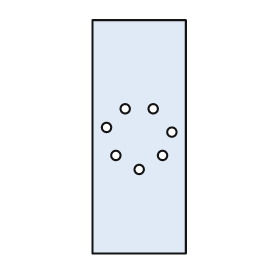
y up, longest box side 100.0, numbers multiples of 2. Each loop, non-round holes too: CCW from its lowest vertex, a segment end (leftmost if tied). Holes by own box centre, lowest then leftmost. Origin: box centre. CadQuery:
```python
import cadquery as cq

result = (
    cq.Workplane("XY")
    .moveTo(-20.0, -50.0)
    .lineTo(20.0, -50.0)
    .lineTo(20.0, 50.0)
    .lineTo(-20.0, 50.0)
    .close()
    .moveTo(0.0, -14.0)
    .circle(2.0)
    .moveTo(-10.0, -8.0)
    .circle(2.0)
    .moveTo(10.0, -8.0)
    .circle(2.0)
    .moveTo(14.0, 2.0)
    .circle(2.0)
    .moveTo(-14.0, 4.0)
    .circle(2.0)
    .moveTo(-6.0, 12.0)
    .circle(2.0)
    .moveTo(6.0, 12.0)
    .circle(2.0)
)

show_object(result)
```